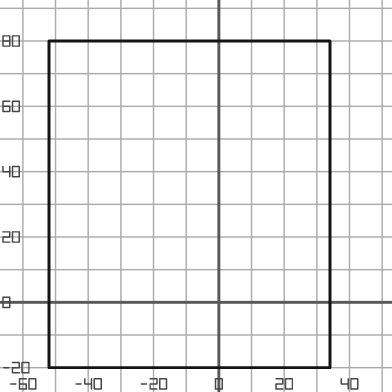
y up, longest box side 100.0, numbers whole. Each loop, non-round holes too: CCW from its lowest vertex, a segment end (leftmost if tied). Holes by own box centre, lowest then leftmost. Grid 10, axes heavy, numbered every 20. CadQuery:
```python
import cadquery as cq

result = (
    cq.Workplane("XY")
    .moveTo(-52.0, -20.0)
    .lineTo(34.0, -20.0)
    .lineTo(34.0, 80.0)
    .lineTo(-52.0, 80.0)
    .close()
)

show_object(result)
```